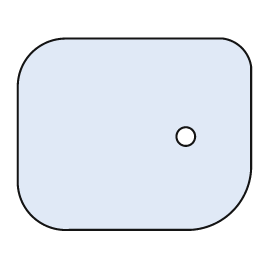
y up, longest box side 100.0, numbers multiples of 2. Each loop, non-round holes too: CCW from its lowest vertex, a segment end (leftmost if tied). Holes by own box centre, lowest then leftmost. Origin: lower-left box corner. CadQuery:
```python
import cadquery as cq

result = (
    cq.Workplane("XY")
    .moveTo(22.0, 0.0)
    .lineTo(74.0, 0.0)
    .threePointArc((92.0, 8.0), (100.0, 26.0))
    .lineTo(100.0, 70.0)
    .threePointArc((96.0, 78.0), (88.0, 82.0))
    .lineTo(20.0, 82.0)
    .threePointArc((6.0, 76.0), (0.0, 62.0))
    .lineTo(0.0, 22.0)
    .threePointArc((6.0, 6.0), (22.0, 0.0))
    .close()
    .moveTo(72.0, 40.0)
    .circle(4.0)
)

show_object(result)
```